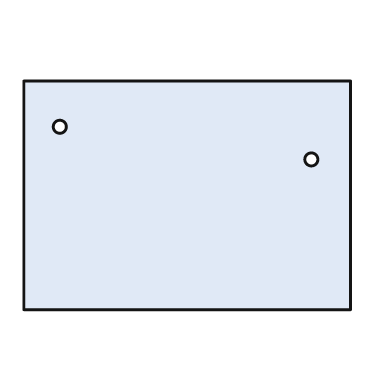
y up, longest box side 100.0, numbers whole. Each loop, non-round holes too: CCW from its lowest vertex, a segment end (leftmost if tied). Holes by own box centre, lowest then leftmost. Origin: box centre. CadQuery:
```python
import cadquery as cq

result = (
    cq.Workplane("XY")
    .moveTo(-50.0, -35.0)
    .lineTo(50.0, -35.0)
    .lineTo(50.0, 35.0)
    .lineTo(-50.0, 35.0)
    .close()
    .moveTo(38.0, 11.0)
    .circle(2.0)
    .moveTo(-39.0, 21.0)
    .circle(2.0)
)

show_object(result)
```